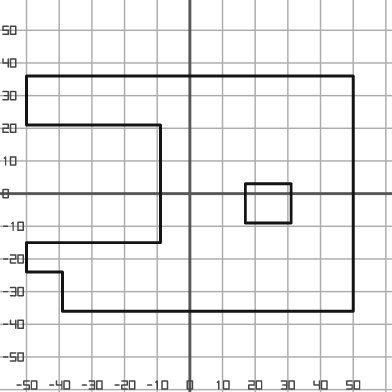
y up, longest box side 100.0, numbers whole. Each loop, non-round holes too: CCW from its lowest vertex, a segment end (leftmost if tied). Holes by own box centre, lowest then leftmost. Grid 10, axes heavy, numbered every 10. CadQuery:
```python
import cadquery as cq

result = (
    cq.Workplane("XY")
    .moveTo(-39.0, -36.0)
    .lineTo(50.0, -36.0)
    .lineTo(50.0, 36.0)
    .lineTo(-50.0, 36.0)
    .lineTo(-50.0, 21.0)
    .lineTo(-9.0, 21.0)
    .lineTo(-9.0, -15.0)
    .lineTo(-50.0, -15.0)
    .lineTo(-50.0, -24.0)
    .lineTo(-39.0, -24.0)
    .close()
    .moveTo(17.0, -9.0)
    .lineTo(31.0, -9.0)
    .lineTo(31.0, 3.0)
    .lineTo(17.0, 3.0)
    .close()
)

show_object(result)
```